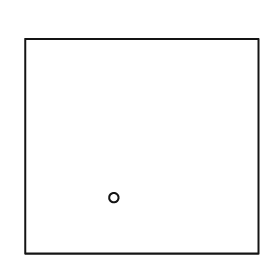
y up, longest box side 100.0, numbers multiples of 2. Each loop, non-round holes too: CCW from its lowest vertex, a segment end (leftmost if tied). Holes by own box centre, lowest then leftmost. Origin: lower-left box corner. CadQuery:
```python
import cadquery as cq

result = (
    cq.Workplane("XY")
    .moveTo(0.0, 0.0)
    .lineTo(100.0, 0.0)
    .lineTo(100.0, 92.0)
    .lineTo(0.0, 92.0)
    .close()
    .moveTo(38.0, 24.0)
    .circle(2.0)
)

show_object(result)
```